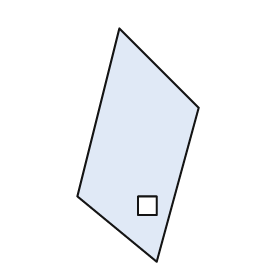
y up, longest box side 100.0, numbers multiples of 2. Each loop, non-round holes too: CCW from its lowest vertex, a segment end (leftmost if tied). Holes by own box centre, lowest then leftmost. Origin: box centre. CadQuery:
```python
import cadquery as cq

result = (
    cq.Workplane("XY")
    .moveTo(8.0, -50.0)
    .lineTo(26.0, 16.0)
    .lineTo(-8.0, 50.0)
    .lineTo(-26.0, -22.0)
    .close()
    .moveTo(0.0, -30.0)
    .lineTo(8.0, -30.0)
    .lineTo(8.0, -22.0)
    .lineTo(0.0, -22.0)
    .close()
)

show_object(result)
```